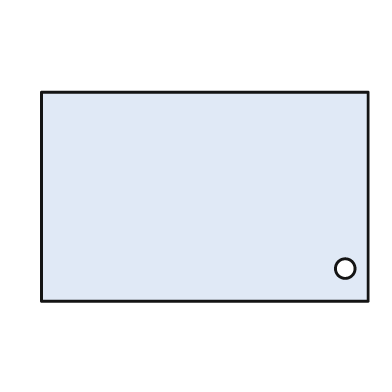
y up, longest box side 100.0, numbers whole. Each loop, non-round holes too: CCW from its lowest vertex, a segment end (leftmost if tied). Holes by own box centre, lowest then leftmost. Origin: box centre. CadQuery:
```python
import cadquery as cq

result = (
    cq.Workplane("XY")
    .moveTo(-50.0, -32.0)
    .lineTo(50.0, -32.0)
    .lineTo(50.0, 32.0)
    .lineTo(-50.0, 32.0)
    .close()
    .moveTo(43.0, -22.0)
    .circle(3.0)
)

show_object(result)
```